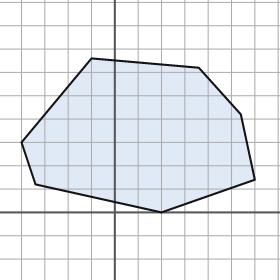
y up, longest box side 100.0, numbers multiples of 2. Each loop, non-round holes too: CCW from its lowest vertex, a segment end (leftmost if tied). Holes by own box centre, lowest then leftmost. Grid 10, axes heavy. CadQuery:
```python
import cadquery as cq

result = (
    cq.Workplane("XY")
    .moveTo(20.0, 0.0)
    .lineTo(60.0, 14.0)
    .lineTo(54.0, 42.0)
    .lineTo(36.0, 62.0)
    .lineTo(-10.0, 66.0)
    .lineTo(-40.0, 30.0)
    .lineTo(-34.0, 12.0)
    .close()
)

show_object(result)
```